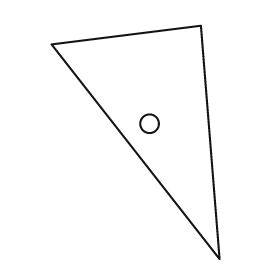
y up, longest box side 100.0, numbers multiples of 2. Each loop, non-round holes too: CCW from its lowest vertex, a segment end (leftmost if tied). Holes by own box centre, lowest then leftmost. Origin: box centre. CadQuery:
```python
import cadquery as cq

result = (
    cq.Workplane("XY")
    .moveTo(36.0, -50.0)
    .lineTo(28.0, 50.0)
    .lineTo(-36.0, 42.0)
    .close()
    .moveTo(6.0, 8.0)
    .circle(4.0)
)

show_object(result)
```